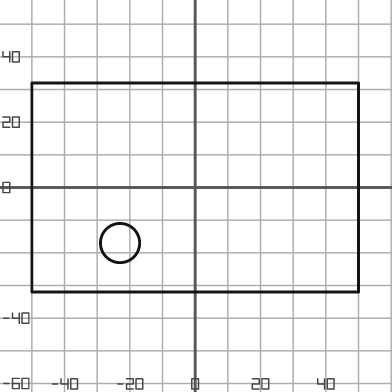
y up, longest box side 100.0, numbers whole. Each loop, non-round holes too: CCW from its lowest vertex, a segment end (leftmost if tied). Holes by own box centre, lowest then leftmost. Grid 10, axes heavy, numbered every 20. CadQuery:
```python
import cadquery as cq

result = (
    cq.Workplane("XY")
    .moveTo(-50.0, -32.0)
    .lineTo(50.0, -32.0)
    .lineTo(50.0, 32.0)
    .lineTo(-50.0, 32.0)
    .close()
    .moveTo(-23.0, -17.0)
    .circle(6.0)
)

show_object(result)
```